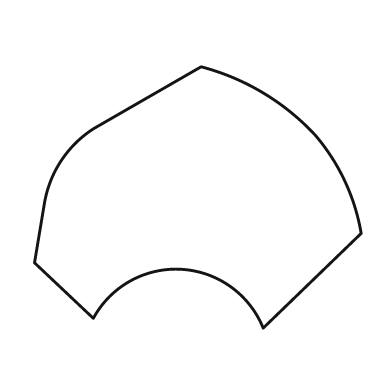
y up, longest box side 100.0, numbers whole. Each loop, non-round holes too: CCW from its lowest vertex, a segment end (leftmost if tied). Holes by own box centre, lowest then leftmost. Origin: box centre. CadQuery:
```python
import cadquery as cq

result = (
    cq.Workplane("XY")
    .moveTo(20.0, -40.0)
    .lineTo(50.0, -11.0)
    .threePointArc((45.0, 5.0), (36.0, 19.0))
    .threePointArc((20.0, 32.0), (1.0, 40.0))
    .lineTo(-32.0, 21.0)
    .threePointArc((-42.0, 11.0), (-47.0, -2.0))
    .lineTo(-50.0, -20.0)
    .lineTo(-32.0, -37.0)
    .threePointArc((-5.0, -22.0), (20.0, -40.0))
    .close()
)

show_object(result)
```